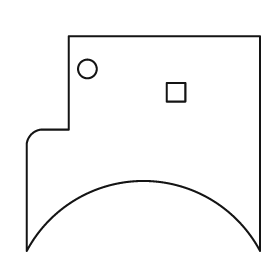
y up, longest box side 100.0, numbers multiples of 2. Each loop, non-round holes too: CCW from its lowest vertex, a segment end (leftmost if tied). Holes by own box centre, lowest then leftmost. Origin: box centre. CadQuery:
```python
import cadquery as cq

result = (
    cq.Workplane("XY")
    .moveTo(-50.0, -46.0)
    .threePointArc((0.0, -16.0), (50.0, -46.0))
    .lineTo(50.0, 46.0)
    .lineTo(-32.0, 46.0)
    .lineTo(-32.0, 6.0)
    .lineTo(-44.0, 6.0)
    .threePointArc((-48.0, 4.0), (-50.0, 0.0))
    .close()
    .moveTo(10.0, 18.0)
    .lineTo(18.0, 18.0)
    .lineTo(18.0, 26.0)
    .lineTo(10.0, 26.0)
    .close()
    .moveTo(-24.0, 32.0)
    .circle(4.0)
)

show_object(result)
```